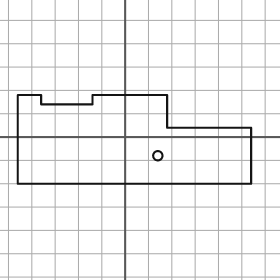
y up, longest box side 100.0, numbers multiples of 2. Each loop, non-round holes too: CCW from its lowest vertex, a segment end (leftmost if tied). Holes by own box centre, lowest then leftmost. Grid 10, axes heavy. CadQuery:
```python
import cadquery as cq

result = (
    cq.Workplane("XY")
    .moveTo(-46.0, -20.0)
    .lineTo(54.0, -20.0)
    .lineTo(54.0, 4.0)
    .lineTo(18.0, 4.0)
    .lineTo(18.0, 18.0)
    .lineTo(-14.0, 18.0)
    .lineTo(-14.0, 14.0)
    .lineTo(-36.0, 14.0)
    .lineTo(-36.0, 18.0)
    .lineTo(-46.0, 18.0)
    .close()
    .moveTo(14.0, -8.0)
    .circle(2.0)
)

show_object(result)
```